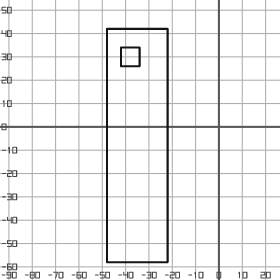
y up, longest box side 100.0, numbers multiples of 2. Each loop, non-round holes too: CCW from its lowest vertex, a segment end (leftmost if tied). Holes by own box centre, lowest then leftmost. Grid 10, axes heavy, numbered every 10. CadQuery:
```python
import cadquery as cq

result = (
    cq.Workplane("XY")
    .moveTo(-48.0, -58.0)
    .lineTo(-22.0, -58.0)
    .lineTo(-22.0, 42.0)
    .lineTo(-48.0, 42.0)
    .close()
    .moveTo(-42.0, 26.0)
    .lineTo(-34.0, 26.0)
    .lineTo(-34.0, 34.0)
    .lineTo(-42.0, 34.0)
    .close()
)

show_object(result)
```